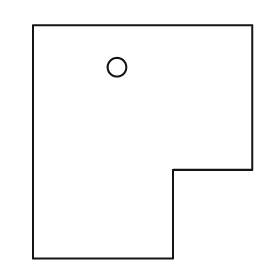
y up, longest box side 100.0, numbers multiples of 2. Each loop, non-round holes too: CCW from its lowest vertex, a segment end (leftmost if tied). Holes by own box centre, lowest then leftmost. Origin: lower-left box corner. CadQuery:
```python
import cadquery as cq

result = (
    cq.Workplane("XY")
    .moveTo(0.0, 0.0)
    .lineTo(60.0, 0.0)
    .lineTo(60.0, 38.0)
    .lineTo(94.0, 38.0)
    .lineTo(94.0, 100.0)
    .lineTo(0.0, 100.0)
    .close()
    .moveTo(36.0, 82.0)
    .circle(4.0)
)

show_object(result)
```